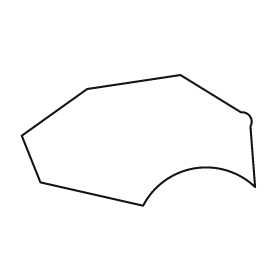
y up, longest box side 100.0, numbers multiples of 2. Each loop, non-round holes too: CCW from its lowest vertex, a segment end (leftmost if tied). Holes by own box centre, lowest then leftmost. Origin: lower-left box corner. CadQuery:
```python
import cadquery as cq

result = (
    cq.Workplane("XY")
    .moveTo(52.0, 0.0)
    .threePointArc((74.0, 16.0), (100.0, 8.0))
    .lineTo(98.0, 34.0)
    .threePointArc((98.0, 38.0), (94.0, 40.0))
    .lineTo(68.0, 56.0)
    .lineTo(28.0, 50.0)
    .lineTo(0.0, 30.0)
    .lineTo(8.0, 10.0)
    .close()
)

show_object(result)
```